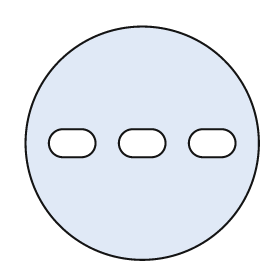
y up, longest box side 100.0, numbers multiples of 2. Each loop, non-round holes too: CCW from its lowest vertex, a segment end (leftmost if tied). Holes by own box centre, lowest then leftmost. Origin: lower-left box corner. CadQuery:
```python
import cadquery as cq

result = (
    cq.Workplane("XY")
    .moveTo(50.0, 50.0)
    .circle(50.0)
    .moveTo(16.0, 44.0)
    .lineTo(24.0, 44.0)
    .threePointArc((30.0, 50.0), (24.0, 56.0))
    .lineTo(16.0, 56.0)
    .threePointArc((10.0, 50.0), (16.0, 44.0))
    .close()
    .moveTo(46.0, 44.0)
    .lineTo(54.0, 44.0)
    .threePointArc((60.0, 50.0), (54.0, 56.0))
    .lineTo(46.0, 56.0)
    .threePointArc((40.0, 50.0), (46.0, 44.0))
    .close()
    .moveTo(76.0, 44.0)
    .lineTo(84.0, 44.0)
    .threePointArc((90.0, 50.0), (84.0, 56.0))
    .lineTo(76.0, 56.0)
    .threePointArc((70.0, 50.0), (76.0, 44.0))
    .close()
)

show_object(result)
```